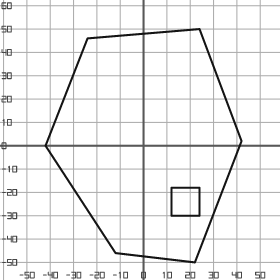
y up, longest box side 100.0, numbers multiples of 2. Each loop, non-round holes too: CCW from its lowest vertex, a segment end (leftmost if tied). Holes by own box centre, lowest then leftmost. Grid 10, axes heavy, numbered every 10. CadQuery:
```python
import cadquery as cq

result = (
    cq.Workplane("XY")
    .moveTo(22.0, -50.0)
    .lineTo(42.0, 2.0)
    .lineTo(24.0, 50.0)
    .lineTo(-24.0, 46.0)
    .lineTo(-42.0, 0.0)
    .lineTo(-12.0, -46.0)
    .close()
    .moveTo(12.0, -30.0)
    .lineTo(24.0, -30.0)
    .lineTo(24.0, -18.0)
    .lineTo(12.0, -18.0)
    .close()
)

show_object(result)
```